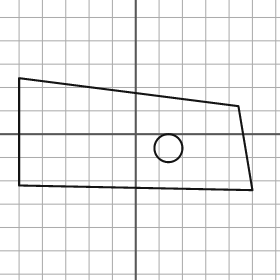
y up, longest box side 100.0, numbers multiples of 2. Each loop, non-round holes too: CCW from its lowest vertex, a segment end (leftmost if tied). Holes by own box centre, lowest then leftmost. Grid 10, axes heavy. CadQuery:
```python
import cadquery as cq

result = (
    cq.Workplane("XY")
    .moveTo(50.0, -24.0)
    .lineTo(44.0, 12.0)
    .lineTo(-50.0, 24.0)
    .lineTo(-50.0, -22.0)
    .close()
    .moveTo(14.0, -6.0)
    .circle(6.0)
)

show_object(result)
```